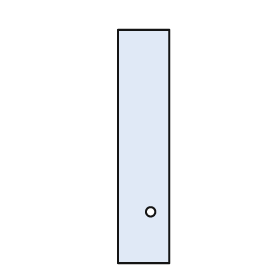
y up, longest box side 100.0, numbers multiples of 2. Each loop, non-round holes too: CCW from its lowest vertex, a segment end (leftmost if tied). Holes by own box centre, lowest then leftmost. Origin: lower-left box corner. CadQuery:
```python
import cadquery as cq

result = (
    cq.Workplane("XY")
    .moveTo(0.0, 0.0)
    .lineTo(22.0, 0.0)
    .lineTo(22.0, 100.0)
    .lineTo(0.0, 100.0)
    .close()
    .moveTo(14.0, 22.0)
    .circle(2.0)
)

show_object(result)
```